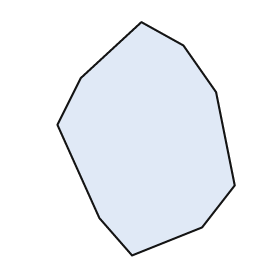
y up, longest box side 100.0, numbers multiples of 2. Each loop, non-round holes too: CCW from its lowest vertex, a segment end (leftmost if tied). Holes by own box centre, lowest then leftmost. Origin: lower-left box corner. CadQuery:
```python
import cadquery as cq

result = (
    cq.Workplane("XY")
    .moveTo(32.0, 0.0)
    .lineTo(62.0, 12.0)
    .lineTo(76.0, 30.0)
    .lineTo(68.0, 70.0)
    .lineTo(54.0, 90.0)
    .lineTo(36.0, 100.0)
    .lineTo(10.0, 76.0)
    .lineTo(0.0, 56.0)
    .lineTo(18.0, 16.0)
    .close()
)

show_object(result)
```